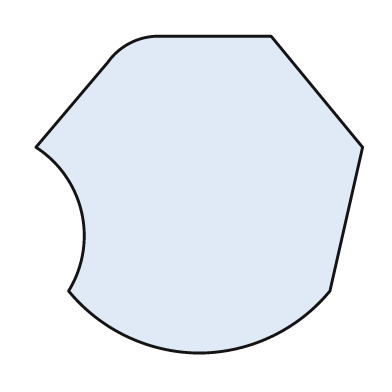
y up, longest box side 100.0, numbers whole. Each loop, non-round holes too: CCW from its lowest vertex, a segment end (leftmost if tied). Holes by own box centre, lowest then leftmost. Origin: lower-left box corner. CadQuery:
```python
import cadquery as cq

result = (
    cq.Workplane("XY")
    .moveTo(50.0, 0.0)
    .threePointArc((72.0, 5.0), (90.0, 19.0))
    .lineTo(100.0, 63.0)
    .lineTo(72.0, 97.0)
    .lineTo(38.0, 97.0)
    .threePointArc((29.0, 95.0), (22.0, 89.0))
    .lineTo(0.0, 63.0)
    .threePointArc((14.0, 43.0), (10.0, 19.0))
    .threePointArc((28.0, 5.0), (50.0, 0.0))
    .close()
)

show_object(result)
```